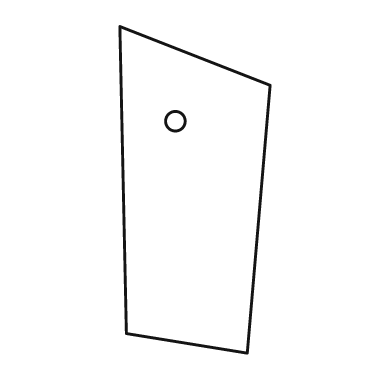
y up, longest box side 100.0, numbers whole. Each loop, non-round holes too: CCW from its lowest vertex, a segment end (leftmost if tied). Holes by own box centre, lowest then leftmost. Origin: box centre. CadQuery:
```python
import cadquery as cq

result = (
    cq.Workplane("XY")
    .moveTo(16.0, -50.0)
    .lineTo(23.0, 32.0)
    .lineTo(-23.0, 50.0)
    .lineTo(-21.0, -44.0)
    .close()
    .moveTo(-6.0, 21.0)
    .circle(3.0)
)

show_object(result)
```